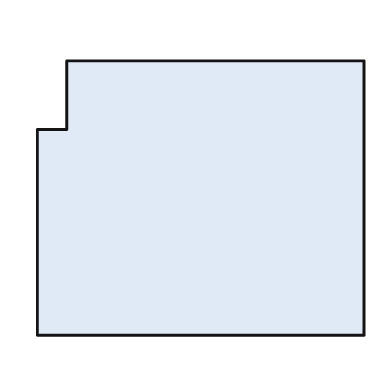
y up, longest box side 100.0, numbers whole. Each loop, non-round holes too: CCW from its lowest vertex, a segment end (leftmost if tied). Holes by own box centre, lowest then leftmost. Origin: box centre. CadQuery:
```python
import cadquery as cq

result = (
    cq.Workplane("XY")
    .moveTo(-50.0, -42.0)
    .lineTo(50.0, -42.0)
    .lineTo(50.0, 42.0)
    .lineTo(-41.0, 42.0)
    .lineTo(-41.0, 21.0)
    .lineTo(-50.0, 21.0)
    .close()
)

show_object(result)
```